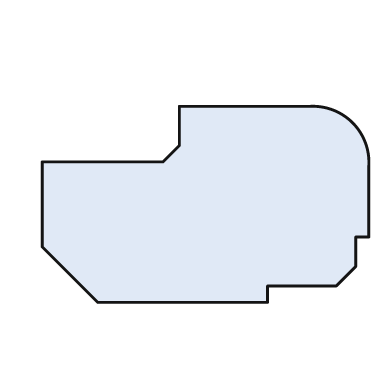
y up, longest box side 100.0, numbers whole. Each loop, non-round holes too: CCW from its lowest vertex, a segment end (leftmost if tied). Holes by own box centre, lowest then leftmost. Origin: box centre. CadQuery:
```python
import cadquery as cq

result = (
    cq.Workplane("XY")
    .moveTo(-33.0, -30.0)
    .lineTo(19.0, -30.0)
    .lineTo(19.0, -25.0)
    .lineTo(40.0, -25.0)
    .lineTo(46.0, -19.0)
    .lineTo(46.0, -10.0)
    .lineTo(50.0, -10.0)
    .lineTo(50.0, 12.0)
    .threePointArc((45.0, 25.0), (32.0, 30.0))
    .lineTo(-8.0, 30.0)
    .lineTo(-8.0, 18.0)
    .lineTo(-13.0, 13.0)
    .lineTo(-50.0, 13.0)
    .lineTo(-50.0, -13.0)
    .close()
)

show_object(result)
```